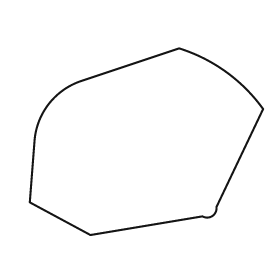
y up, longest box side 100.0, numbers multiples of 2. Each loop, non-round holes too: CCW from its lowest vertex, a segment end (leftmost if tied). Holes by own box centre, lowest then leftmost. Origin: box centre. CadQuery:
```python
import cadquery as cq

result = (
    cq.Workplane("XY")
    .moveTo(-24.0, -40.0)
    .lineTo(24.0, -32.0)
    .threePointArc((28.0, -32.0), (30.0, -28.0))
    .lineTo(50.0, 14.0)
    .threePointArc((34.0, 30.0), (14.0, 40.0))
    .lineTo(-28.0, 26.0)
    .threePointArc((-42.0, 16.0), (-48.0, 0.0))
    .lineTo(-50.0, -26.0)
    .close()
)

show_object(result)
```